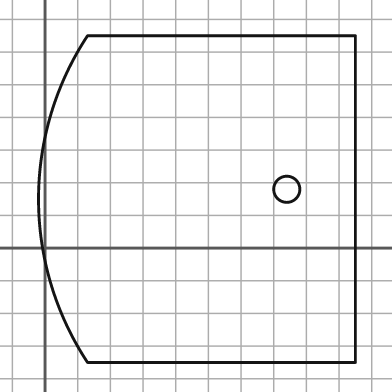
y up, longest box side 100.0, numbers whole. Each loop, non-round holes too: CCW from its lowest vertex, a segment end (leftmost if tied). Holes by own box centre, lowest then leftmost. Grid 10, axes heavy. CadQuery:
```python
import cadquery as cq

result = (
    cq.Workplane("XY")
    .moveTo(13.0, -35.0)
    .lineTo(95.0, -35.0)
    .lineTo(95.0, 65.0)
    .lineTo(13.0, 65.0)
    .threePointArc((-2.0, 15.0), (13.0, -35.0))
    .close()
    .moveTo(74.0, 18.0)
    .circle(4.0)
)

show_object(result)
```